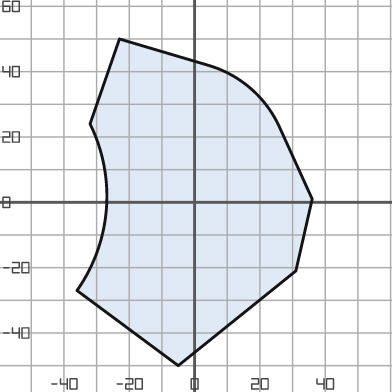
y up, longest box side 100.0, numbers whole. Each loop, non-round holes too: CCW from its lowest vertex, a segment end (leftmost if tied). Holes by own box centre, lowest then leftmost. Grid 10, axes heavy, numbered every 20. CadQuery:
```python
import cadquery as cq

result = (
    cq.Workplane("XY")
    .moveTo(-5.0, -50.0)
    .lineTo(31.0, -21.0)
    .lineTo(36.0, 1.0)
    .lineTo(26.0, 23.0)
    .threePointArc((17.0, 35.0), (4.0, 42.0))
    .lineTo(-23.0, 50.0)
    .lineTo(-32.0, 24.0)
    .threePointArc((-27.0, -2.0), (-36.0, -27.0))
    .close()
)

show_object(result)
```